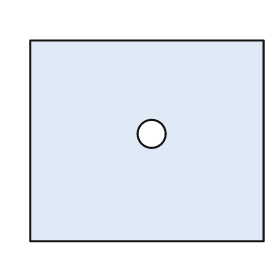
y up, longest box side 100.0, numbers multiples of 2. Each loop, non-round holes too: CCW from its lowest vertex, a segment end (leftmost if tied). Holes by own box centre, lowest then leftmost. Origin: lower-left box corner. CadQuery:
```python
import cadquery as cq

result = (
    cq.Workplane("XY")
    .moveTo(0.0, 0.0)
    .lineTo(100.0, 0.0)
    .lineTo(100.0, 86.0)
    .lineTo(0.0, 86.0)
    .close()
    .moveTo(52.0, 46.0)
    .circle(6.0)
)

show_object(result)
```